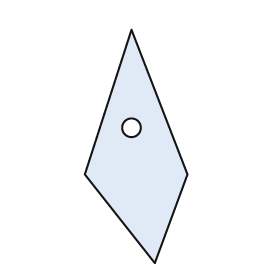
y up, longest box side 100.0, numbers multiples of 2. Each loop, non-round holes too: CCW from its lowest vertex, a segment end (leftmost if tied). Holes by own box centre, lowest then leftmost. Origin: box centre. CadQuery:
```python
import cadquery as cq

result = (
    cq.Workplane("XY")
    .moveTo(8.0, -50.0)
    .lineTo(22.0, -12.0)
    .lineTo(-2.0, 50.0)
    .lineTo(-22.0, -12.0)
    .close()
    .moveTo(-2.0, 8.0)
    .circle(4.0)
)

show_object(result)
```